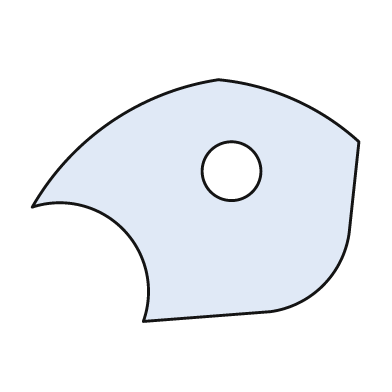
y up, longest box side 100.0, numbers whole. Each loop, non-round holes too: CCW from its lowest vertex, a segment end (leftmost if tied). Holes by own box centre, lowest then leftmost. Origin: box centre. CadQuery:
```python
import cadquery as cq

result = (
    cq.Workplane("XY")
    .moveTo(-16.0, -37.0)
    .lineTo(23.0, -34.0)
    .threePointArc((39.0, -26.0), (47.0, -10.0))
    .lineTo(50.0, 18.0)
    .threePointArc((30.0, 31.0), (7.0, 37.0))
    .threePointArc((-26.0, 24.0), (-50.0, -2.0))
    .threePointArc((-22.0, -9.0), (-16.0, -37.0))
    .close()
    .moveTo(11.0, 9.0)
    .circle(9.0)
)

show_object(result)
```